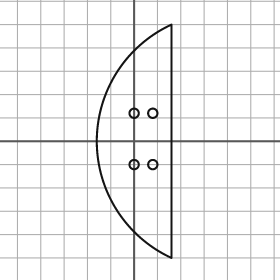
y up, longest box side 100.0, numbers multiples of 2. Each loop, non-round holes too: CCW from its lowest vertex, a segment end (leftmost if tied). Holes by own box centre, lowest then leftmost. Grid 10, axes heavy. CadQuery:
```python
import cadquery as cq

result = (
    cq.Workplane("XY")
    .moveTo(16.0, -50.0)
    .lineTo(16.0, 50.0)
    .threePointArc((-16.0, 0.0), (16.0, -50.0))
    .close()
    .moveTo(0.0, -10.0)
    .circle(2.0)
    .moveTo(8.0, -10.0)
    .circle(2.0)
    .moveTo(0.0, 12.0)
    .circle(2.0)
    .moveTo(8.0, 12.0)
    .circle(2.0)
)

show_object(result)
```